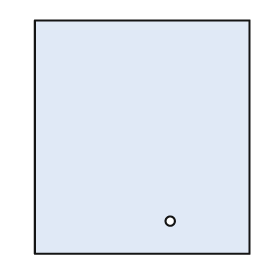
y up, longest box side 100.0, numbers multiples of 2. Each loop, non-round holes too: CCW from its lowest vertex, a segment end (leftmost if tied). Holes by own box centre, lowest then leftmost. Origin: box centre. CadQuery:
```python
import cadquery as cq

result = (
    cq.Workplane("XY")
    .moveTo(-46.0, -50.0)
    .lineTo(46.0, -50.0)
    .lineTo(46.0, 50.0)
    .lineTo(-46.0, 50.0)
    .close()
    .moveTo(12.0, -36.0)
    .circle(2.0)
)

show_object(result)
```